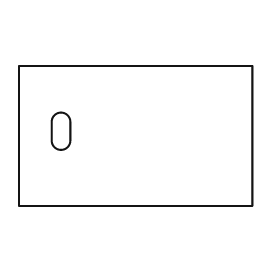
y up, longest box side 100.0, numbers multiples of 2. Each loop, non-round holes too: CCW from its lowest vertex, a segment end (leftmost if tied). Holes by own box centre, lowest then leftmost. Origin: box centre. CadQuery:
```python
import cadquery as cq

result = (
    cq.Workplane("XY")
    .moveTo(-50.0, -30.0)
    .lineTo(50.0, -30.0)
    .lineTo(50.0, 30.0)
    .lineTo(-50.0, 30.0)
    .close()
    .moveTo(-36.0, -2.0)
    .threePointArc((-32.0, -6.0), (-28.0, -2.0))
    .lineTo(-28.0, 6.0)
    .threePointArc((-32.0, 10.0), (-36.0, 6.0))
    .close()
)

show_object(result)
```